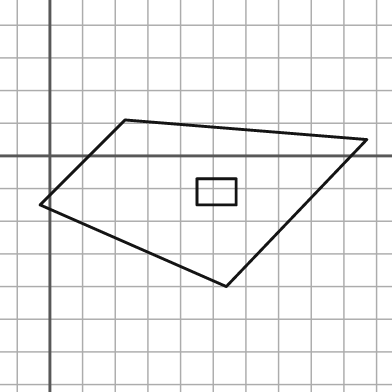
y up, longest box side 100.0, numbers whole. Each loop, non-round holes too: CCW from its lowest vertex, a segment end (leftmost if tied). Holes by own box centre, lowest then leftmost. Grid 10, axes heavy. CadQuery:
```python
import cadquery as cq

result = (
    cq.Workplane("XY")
    .moveTo(54.0, -40.0)
    .lineTo(97.0, 5.0)
    .lineTo(23.0, 11.0)
    .lineTo(-3.0, -15.0)
    .close()
    .moveTo(45.0, -15.0)
    .lineTo(57.0, -15.0)
    .lineTo(57.0, -7.0)
    .lineTo(45.0, -7.0)
    .close()
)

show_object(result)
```